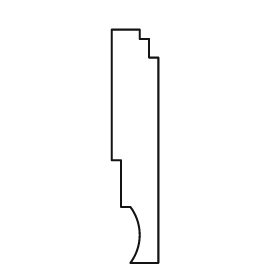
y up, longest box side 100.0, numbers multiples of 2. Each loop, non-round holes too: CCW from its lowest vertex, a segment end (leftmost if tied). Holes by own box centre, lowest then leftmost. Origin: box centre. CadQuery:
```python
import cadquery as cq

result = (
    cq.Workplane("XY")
    .moveTo(-2.0, -50.0)
    .lineTo(10.0, -50.0)
    .lineTo(10.0, 38.0)
    .lineTo(6.0, 38.0)
    .lineTo(6.0, 46.0)
    .lineTo(2.0, 46.0)
    .lineTo(2.0, 50.0)
    .lineTo(-10.0, 50.0)
    .lineTo(-10.0, -6.0)
    .lineTo(-6.0, -6.0)
    .lineTo(-6.0, -26.0)
    .lineTo(-2.0, -26.0)
    .threePointArc((2.0, -38.0), (-2.0, -50.0))
    .close()
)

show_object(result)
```